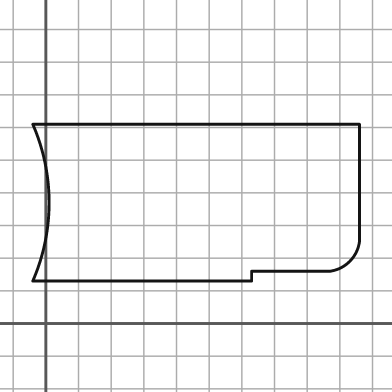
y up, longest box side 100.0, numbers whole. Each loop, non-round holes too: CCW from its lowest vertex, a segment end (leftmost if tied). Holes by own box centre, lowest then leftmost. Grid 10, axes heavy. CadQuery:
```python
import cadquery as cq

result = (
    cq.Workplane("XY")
    .moveTo(-4.0, 13.0)
    .lineTo(63.0, 13.0)
    .lineTo(63.0, 16.0)
    .lineTo(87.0, 16.0)
    .threePointArc((93.0, 19.0), (96.0, 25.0))
    .lineTo(96.0, 61.0)
    .lineTo(-4.0, 61.0)
    .threePointArc((1.0, 37.0), (-4.0, 13.0))
    .close()
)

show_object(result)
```